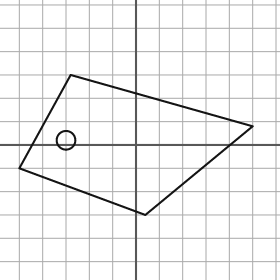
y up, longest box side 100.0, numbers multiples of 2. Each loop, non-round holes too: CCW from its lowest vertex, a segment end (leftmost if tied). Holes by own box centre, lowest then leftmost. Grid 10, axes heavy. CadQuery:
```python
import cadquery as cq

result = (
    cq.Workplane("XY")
    .moveTo(4.0, -30.0)
    .lineTo(50.0, 8.0)
    .lineTo(-28.0, 30.0)
    .lineTo(-50.0, -10.0)
    .close()
    .moveTo(-30.0, 2.0)
    .circle(4.0)
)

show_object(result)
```